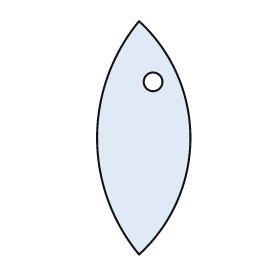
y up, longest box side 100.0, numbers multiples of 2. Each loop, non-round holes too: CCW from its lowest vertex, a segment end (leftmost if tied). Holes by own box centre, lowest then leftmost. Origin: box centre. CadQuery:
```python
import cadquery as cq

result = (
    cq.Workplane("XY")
    .moveTo(-2.0, -50.0)
    .threePointArc((20.0, 0.0), (-2.0, 50.0))
    .threePointArc((-20.0, 0.0), (-2.0, -50.0))
    .close()
    .moveTo(4.0, 24.0)
    .circle(4.0)
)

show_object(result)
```